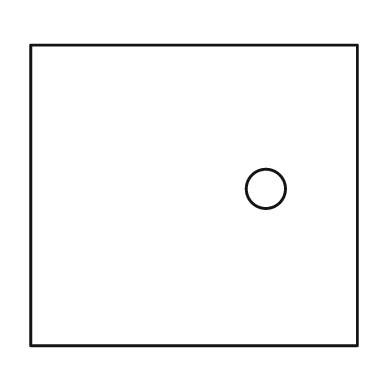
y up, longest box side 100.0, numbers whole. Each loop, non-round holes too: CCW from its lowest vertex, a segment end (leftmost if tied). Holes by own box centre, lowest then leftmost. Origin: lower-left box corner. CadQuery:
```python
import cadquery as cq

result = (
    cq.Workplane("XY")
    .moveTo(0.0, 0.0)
    .lineTo(100.0, 0.0)
    .lineTo(100.0, 92.0)
    .lineTo(0.0, 92.0)
    .close()
    .moveTo(72.0, 48.0)
    .circle(6.0)
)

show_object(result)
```